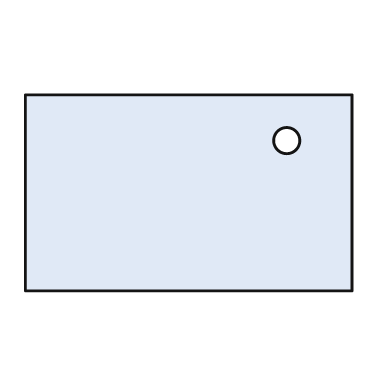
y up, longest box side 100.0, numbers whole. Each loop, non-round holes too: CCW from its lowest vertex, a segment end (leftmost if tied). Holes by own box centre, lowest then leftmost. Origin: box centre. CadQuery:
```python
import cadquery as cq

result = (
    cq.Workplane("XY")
    .moveTo(-50.0, -30.0)
    .lineTo(50.0, -30.0)
    .lineTo(50.0, 30.0)
    .lineTo(-50.0, 30.0)
    .close()
    .moveTo(30.0, 16.0)
    .circle(4.0)
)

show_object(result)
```